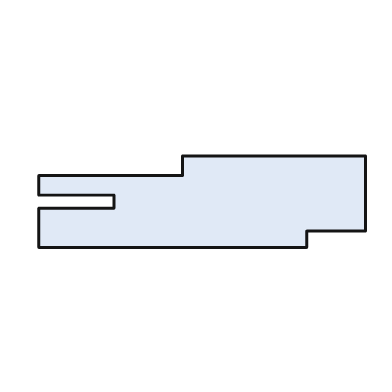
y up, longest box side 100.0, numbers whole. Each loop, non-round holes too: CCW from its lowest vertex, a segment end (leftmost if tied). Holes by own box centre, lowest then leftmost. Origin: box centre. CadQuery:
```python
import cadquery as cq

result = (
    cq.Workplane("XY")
    .moveTo(-50.0, -14.0)
    .lineTo(32.0, -14.0)
    .lineTo(32.0, -9.0)
    .lineTo(50.0, -9.0)
    .lineTo(50.0, 14.0)
    .lineTo(-6.0, 14.0)
    .lineTo(-6.0, 8.0)
    .lineTo(-50.0, 8.0)
    .lineTo(-50.0, 2.0)
    .lineTo(-27.0, 2.0)
    .lineTo(-27.0, -2.0)
    .lineTo(-50.0, -2.0)
    .close()
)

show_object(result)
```